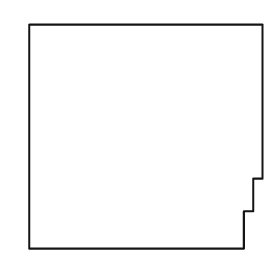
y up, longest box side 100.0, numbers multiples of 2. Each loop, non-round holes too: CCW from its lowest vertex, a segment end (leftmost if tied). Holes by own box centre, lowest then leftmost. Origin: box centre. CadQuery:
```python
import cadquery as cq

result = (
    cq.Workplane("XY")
    .moveTo(-50.0, -48.0)
    .lineTo(42.0, -48.0)
    .lineTo(42.0, -32.0)
    .lineTo(46.0, -32.0)
    .lineTo(46.0, -18.0)
    .lineTo(50.0, -18.0)
    .lineTo(50.0, 48.0)
    .lineTo(-50.0, 48.0)
    .close()
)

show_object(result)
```